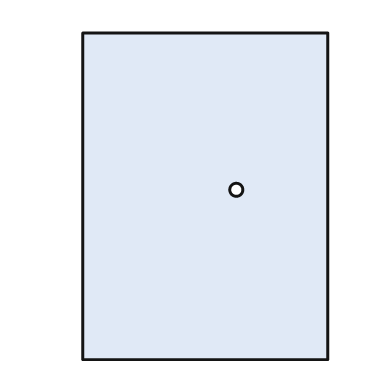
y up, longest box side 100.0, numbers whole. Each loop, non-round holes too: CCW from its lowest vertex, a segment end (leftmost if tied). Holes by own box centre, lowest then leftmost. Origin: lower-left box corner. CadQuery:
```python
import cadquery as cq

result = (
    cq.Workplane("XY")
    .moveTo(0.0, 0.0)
    .lineTo(75.0, 0.0)
    .lineTo(75.0, 100.0)
    .lineTo(0.0, 100.0)
    .close()
    .moveTo(47.0, 52.0)
    .circle(2.0)
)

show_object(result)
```